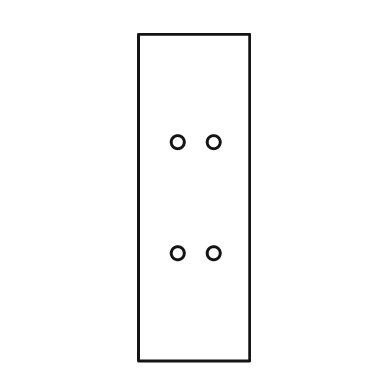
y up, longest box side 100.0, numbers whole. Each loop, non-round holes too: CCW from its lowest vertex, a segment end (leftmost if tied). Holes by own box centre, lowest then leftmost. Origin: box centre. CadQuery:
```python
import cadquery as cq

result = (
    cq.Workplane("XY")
    .moveTo(-17.0, -50.0)
    .lineTo(17.0, -50.0)
    .lineTo(17.0, 50.0)
    .lineTo(-17.0, 50.0)
    .close()
    .moveTo(-5.0, -17.0)
    .circle(2.0)
    .moveTo(6.0, -17.0)
    .circle(2.0)
    .moveTo(-5.0, 17.0)
    .circle(2.0)
    .moveTo(6.0, 17.0)
    .circle(2.0)
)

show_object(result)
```